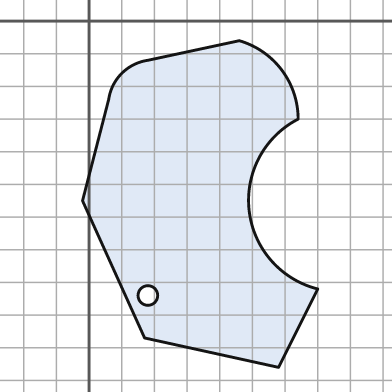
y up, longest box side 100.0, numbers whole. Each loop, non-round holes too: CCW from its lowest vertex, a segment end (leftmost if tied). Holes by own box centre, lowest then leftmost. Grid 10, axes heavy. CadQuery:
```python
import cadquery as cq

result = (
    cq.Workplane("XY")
    .moveTo(58.0, -106.0)
    .lineTo(70.0, -82.0)
    .threePointArc((49.0, -58.0), (64.0, -30.0))
    .threePointArc((59.0, -15.0), (46.0, -6.0))
    .lineTo(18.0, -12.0)
    .threePointArc((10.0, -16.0), (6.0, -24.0))
    .lineTo(-2.0, -55.0)
    .lineTo(17.0, -97.0)
    .close()
    .moveTo(18.0, -84.0)
    .circle(3.0)
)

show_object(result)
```